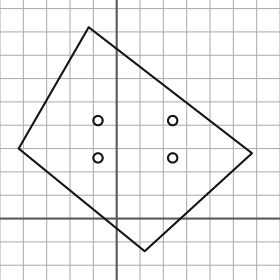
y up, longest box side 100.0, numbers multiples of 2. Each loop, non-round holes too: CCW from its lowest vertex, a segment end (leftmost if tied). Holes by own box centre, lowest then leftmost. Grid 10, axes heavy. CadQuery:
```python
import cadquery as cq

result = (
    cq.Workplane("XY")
    .moveTo(12.0, -14.0)
    .lineTo(58.0, 28.0)
    .lineTo(-12.0, 82.0)
    .lineTo(-42.0, 30.0)
    .close()
    .moveTo(-8.0, 26.0)
    .circle(2.0)
    .moveTo(24.0, 26.0)
    .circle(2.0)
    .moveTo(-8.0, 42.0)
    .circle(2.0)
    .moveTo(24.0, 42.0)
    .circle(2.0)
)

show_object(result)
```